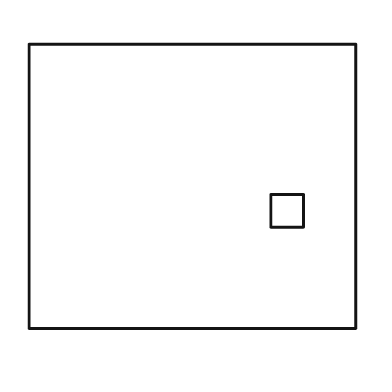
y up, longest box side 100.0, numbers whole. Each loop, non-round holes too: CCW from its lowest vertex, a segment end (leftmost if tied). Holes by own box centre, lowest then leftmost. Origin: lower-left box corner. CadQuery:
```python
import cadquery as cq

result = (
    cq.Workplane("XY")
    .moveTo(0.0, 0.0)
    .lineTo(100.0, 0.0)
    .lineTo(100.0, 87.0)
    .lineTo(0.0, 87.0)
    .close()
    .moveTo(74.0, 31.0)
    .lineTo(84.0, 31.0)
    .lineTo(84.0, 41.0)
    .lineTo(74.0, 41.0)
    .close()
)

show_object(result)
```